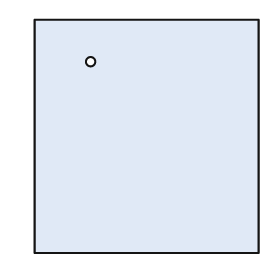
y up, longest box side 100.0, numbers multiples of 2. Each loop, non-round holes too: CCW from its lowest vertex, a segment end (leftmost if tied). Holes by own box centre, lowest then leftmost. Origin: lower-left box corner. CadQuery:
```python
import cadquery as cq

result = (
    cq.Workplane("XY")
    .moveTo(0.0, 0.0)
    .lineTo(96.0, 0.0)
    .lineTo(96.0, 100.0)
    .lineTo(0.0, 100.0)
    .close()
    .moveTo(24.0, 82.0)
    .circle(2.0)
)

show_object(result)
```